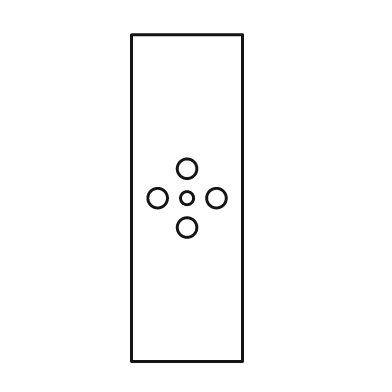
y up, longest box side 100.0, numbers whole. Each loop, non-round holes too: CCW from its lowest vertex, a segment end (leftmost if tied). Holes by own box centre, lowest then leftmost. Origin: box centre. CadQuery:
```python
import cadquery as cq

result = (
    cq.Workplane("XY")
    .moveTo(-17.0, -50.0)
    .lineTo(17.0, -50.0)
    .lineTo(17.0, 50.0)
    .lineTo(-17.0, 50.0)
    .close()
    .moveTo(0.0, -9.0)
    .circle(3.0)
    .moveTo(-9.0, 0.0)
    .circle(3.0)
    .moveTo(0.0, 0.0)
    .circle(2.0)
    .moveTo(9.0, 0.0)
    .circle(3.0)
    .moveTo(0.0, 9.0)
    .circle(3.0)
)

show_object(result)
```